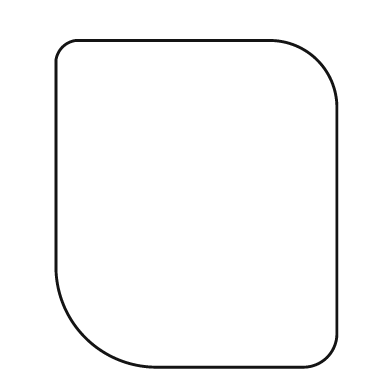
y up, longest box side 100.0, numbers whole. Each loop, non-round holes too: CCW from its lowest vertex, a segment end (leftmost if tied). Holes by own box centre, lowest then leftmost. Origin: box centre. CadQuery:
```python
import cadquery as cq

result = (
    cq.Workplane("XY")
    .moveTo(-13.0, -50.0)
    .lineTo(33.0, -50.0)
    .threePointArc((40.0, -47.0), (43.0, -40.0))
    .lineTo(43.0, 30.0)
    .threePointArc((37.0, 44.0), (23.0, 50.0))
    .lineTo(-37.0, 50.0)
    .threePointArc((-41.0, 48.0), (-43.0, 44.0))
    .lineTo(-43.0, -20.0)
    .threePointArc((-34.0, -41.0), (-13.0, -50.0))
    .close()
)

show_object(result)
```